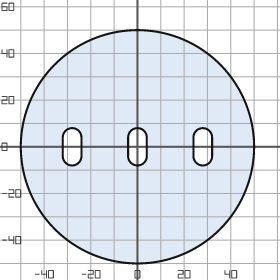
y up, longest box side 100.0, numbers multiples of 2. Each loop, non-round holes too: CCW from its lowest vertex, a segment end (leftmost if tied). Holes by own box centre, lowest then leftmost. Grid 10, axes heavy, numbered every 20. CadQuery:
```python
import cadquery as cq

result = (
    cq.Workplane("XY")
    .moveTo(0.0, 0.0)
    .circle(50.0)
    .moveTo(-32.0, -4.0)
    .threePointArc((-28.0, -8.0), (-24.0, -4.0))
    .lineTo(-24.0, 4.0)
    .threePointArc((-28.0, 8.0), (-32.0, 4.0))
    .close()
    .moveTo(-4.0, -4.0)
    .threePointArc((0.0, -8.0), (4.0, -4.0))
    .lineTo(4.0, 4.0)
    .threePointArc((0.0, 8.0), (-4.0, 4.0))
    .close()
    .moveTo(24.0, -4.0)
    .threePointArc((28.0, -8.0), (32.0, -4.0))
    .lineTo(32.0, 4.0)
    .threePointArc((28.0, 8.0), (24.0, 4.0))
    .close()
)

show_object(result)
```